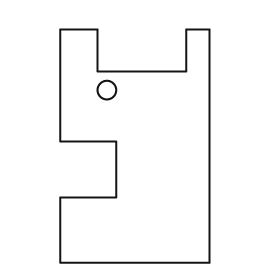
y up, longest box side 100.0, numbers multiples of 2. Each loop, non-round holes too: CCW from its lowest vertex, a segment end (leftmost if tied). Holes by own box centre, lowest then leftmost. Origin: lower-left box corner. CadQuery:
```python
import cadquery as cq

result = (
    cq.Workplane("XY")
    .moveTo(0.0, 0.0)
    .lineTo(64.0, 0.0)
    .lineTo(64.0, 100.0)
    .lineTo(54.0, 100.0)
    .lineTo(54.0, 82.0)
    .lineTo(16.0, 82.0)
    .lineTo(16.0, 100.0)
    .lineTo(0.0, 100.0)
    .lineTo(0.0, 52.0)
    .lineTo(24.0, 52.0)
    .lineTo(24.0, 28.0)
    .lineTo(0.0, 28.0)
    .close()
    .moveTo(20.0, 74.0)
    .circle(4.0)
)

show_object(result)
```